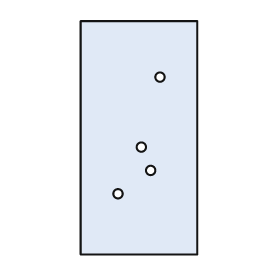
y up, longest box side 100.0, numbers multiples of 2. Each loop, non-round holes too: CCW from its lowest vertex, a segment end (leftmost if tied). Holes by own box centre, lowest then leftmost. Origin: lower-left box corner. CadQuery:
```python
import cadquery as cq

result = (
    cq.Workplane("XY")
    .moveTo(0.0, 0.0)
    .lineTo(50.0, 0.0)
    .lineTo(50.0, 100.0)
    .lineTo(0.0, 100.0)
    .close()
    .moveTo(16.0, 26.0)
    .circle(2.0)
    .moveTo(30.0, 36.0)
    .circle(2.0)
    .moveTo(26.0, 46.0)
    .circle(2.0)
    .moveTo(34.0, 76.0)
    .circle(2.0)
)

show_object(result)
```